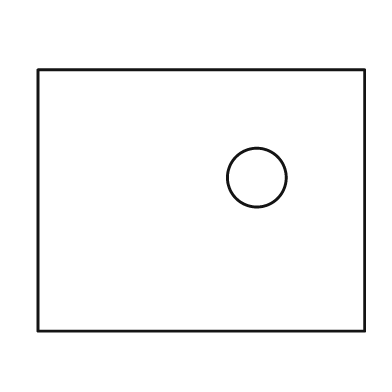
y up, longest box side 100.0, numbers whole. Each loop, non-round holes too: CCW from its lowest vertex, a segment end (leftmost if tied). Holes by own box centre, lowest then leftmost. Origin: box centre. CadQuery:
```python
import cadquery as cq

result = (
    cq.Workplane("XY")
    .moveTo(-50.0, -40.0)
    .lineTo(50.0, -40.0)
    .lineTo(50.0, 40.0)
    .lineTo(-50.0, 40.0)
    .close()
    .moveTo(17.0, 7.0)
    .circle(9.0)
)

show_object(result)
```